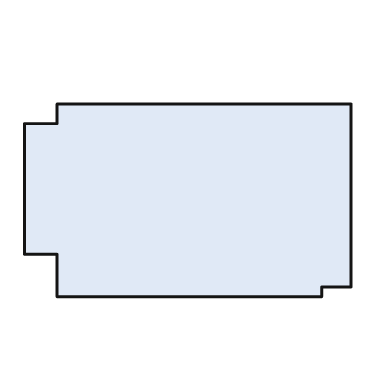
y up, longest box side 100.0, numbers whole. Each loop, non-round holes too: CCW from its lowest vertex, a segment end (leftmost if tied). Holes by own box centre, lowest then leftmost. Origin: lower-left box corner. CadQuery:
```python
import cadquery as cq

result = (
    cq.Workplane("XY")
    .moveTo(10.0, 0.0)
    .lineTo(91.0, 0.0)
    .lineTo(91.0, 3.0)
    .lineTo(100.0, 3.0)
    .lineTo(100.0, 59.0)
    .lineTo(10.0, 59.0)
    .lineTo(10.0, 53.0)
    .lineTo(0.0, 53.0)
    .lineTo(0.0, 13.0)
    .lineTo(10.0, 13.0)
    .close()
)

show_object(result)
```